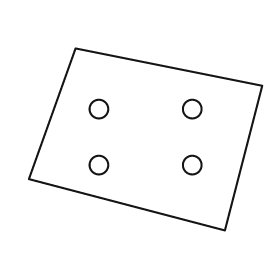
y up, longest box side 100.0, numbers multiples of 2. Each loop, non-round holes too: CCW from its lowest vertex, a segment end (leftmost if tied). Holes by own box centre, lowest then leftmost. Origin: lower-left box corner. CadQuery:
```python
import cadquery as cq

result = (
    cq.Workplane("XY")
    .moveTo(84.0, 0.0)
    .lineTo(100.0, 62.0)
    .lineTo(20.0, 78.0)
    .lineTo(0.0, 22.0)
    .close()
    .moveTo(30.0, 28.0)
    .circle(4.0)
    .moveTo(70.0, 28.0)
    .circle(4.0)
    .moveTo(30.0, 52.0)
    .circle(4.0)
    .moveTo(70.0, 52.0)
    .circle(4.0)
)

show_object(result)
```